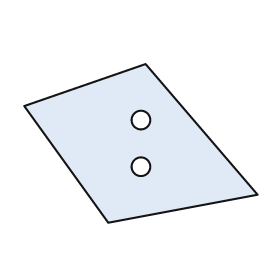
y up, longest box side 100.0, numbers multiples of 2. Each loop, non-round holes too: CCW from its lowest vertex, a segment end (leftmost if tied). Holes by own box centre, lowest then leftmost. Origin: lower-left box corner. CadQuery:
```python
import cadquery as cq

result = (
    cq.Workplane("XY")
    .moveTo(36.0, 0.0)
    .lineTo(100.0, 12.0)
    .lineTo(52.0, 68.0)
    .lineTo(0.0, 50.0)
    .close()
    .moveTo(50.0, 24.0)
    .circle(4.0)
    .moveTo(50.0, 44.0)
    .circle(4.0)
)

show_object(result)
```